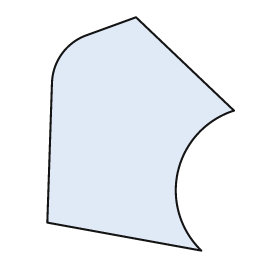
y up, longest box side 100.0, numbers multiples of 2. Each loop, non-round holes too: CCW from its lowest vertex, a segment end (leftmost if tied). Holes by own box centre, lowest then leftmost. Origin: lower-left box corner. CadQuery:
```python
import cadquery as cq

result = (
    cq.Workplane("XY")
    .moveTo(66.0, 0.0)
    .threePointArc((56.0, 34.0), (80.0, 60.0))
    .lineTo(38.0, 100.0)
    .lineTo(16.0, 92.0)
    .threePointArc((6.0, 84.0), (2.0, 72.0))
    .lineTo(0.0, 12.0)
    .close()
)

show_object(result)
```